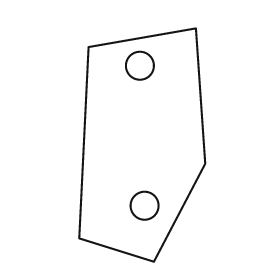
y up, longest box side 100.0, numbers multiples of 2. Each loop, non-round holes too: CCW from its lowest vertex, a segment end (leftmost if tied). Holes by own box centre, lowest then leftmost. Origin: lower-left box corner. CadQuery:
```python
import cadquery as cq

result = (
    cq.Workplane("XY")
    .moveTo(32.0, 0.0)
    .lineTo(54.0, 42.0)
    .lineTo(50.0, 100.0)
    .lineTo(4.0, 92.0)
    .lineTo(0.0, 10.0)
    .close()
    .moveTo(28.0, 24.0)
    .circle(6.0)
    .moveTo(26.0, 84.0)
    .circle(6.0)
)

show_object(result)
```